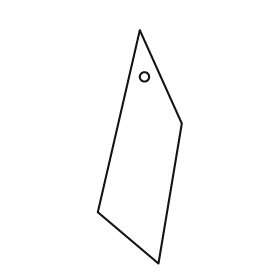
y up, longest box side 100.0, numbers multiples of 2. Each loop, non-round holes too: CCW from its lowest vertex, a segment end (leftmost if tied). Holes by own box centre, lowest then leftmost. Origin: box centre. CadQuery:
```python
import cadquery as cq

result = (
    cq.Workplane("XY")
    .moveTo(8.0, -50.0)
    .lineTo(18.0, 10.0)
    .lineTo(0.0, 50.0)
    .lineTo(-18.0, -28.0)
    .close()
    .moveTo(2.0, 30.0)
    .circle(2.0)
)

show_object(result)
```